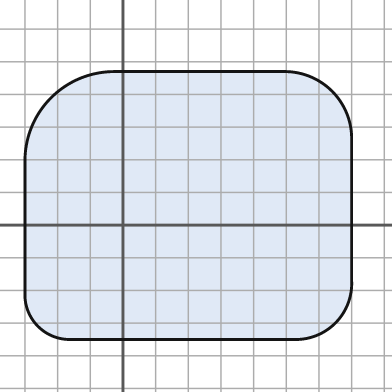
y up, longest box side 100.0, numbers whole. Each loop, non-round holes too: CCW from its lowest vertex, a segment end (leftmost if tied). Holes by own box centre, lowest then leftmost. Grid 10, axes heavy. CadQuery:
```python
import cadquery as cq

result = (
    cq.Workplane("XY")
    .moveTo(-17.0, -35.0)
    .lineTo(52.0, -35.0)
    .threePointArc((65.0, -30.0), (70.0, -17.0))
    .lineTo(70.0, 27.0)
    .threePointArc((64.0, 41.0), (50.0, 47.0))
    .lineTo(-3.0, 47.0)
    .threePointArc((-22.0, 39.0), (-30.0, 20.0))
    .lineTo(-30.0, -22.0)
    .threePointArc((-26.0, -31.0), (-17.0, -35.0))
    .close()
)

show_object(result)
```